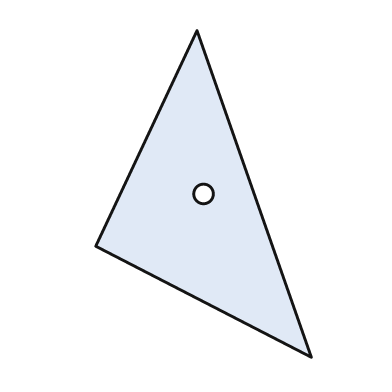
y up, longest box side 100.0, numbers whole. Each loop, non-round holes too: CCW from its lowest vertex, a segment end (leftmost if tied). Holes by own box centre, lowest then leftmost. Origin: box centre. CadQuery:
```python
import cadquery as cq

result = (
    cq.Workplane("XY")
    .moveTo(33.0, -50.0)
    .lineTo(-2.0, 50.0)
    .lineTo(-33.0, -16.0)
    .close()
    .moveTo(0.0, 0.0)
    .circle(3.0)
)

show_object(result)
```